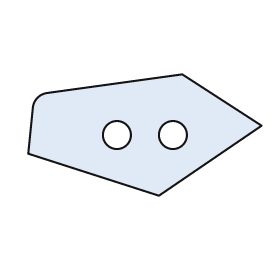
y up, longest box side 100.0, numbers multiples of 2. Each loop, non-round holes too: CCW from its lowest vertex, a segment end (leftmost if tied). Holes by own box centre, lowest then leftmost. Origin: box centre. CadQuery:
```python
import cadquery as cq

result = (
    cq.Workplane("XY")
    .moveTo(6.0, -26.0)
    .lineTo(50.0, 4.0)
    .lineTo(16.0, 26.0)
    .lineTo(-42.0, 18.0)
    .threePointArc((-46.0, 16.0), (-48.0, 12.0))
    .lineTo(-50.0, -8.0)
    .close()
    .moveTo(-12.0, 0.0)
    .circle(6.0)
    .moveTo(12.0, 0.0)
    .circle(6.0)
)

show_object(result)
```